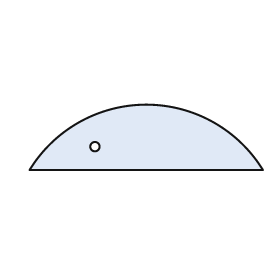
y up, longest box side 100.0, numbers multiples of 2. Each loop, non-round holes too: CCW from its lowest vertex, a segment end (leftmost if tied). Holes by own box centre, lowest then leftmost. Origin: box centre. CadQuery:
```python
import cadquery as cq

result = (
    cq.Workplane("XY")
    .moveTo(-50.0, -14.0)
    .lineTo(50.0, -14.0)
    .threePointArc((0.0, 14.0), (-50.0, -14.0))
    .close()
    .moveTo(-22.0, -4.0)
    .circle(2.0)
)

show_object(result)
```